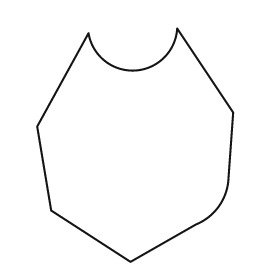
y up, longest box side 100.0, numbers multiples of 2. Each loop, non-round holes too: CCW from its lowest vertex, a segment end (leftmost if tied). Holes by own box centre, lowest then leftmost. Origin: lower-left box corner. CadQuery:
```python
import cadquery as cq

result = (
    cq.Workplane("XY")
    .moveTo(40.0, 0.0)
    .lineTo(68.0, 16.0)
    .threePointArc((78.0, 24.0), (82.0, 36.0))
    .lineTo(84.0, 64.0)
    .lineTo(60.0, 100.0)
    .threePointArc((42.0, 82.0), (22.0, 98.0))
    .lineTo(0.0, 58.0)
    .lineTo(6.0, 22.0)
    .close()
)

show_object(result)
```